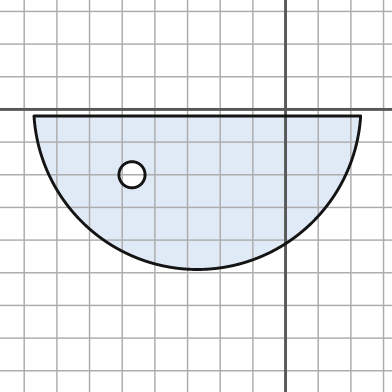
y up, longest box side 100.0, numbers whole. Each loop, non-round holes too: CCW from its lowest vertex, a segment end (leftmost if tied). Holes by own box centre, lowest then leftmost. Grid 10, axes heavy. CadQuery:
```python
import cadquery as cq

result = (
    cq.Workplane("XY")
    .moveTo(-77.0, -2.0)
    .threePointArc((-27.0, -49.0), (23.0, -2.0))
    .close()
    .moveTo(-47.0, -20.0)
    .circle(4.0)
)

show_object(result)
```